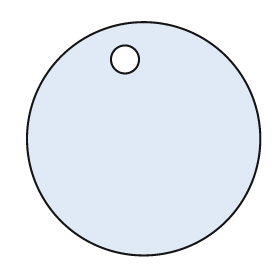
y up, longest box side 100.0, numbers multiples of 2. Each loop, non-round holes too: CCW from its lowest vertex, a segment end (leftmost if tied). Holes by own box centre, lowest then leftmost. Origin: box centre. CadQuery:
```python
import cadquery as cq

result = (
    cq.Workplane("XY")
    .moveTo(0.0, 0.0)
    .circle(50.0)
    .moveTo(-8.0, 34.0)
    .circle(6.0)
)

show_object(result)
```